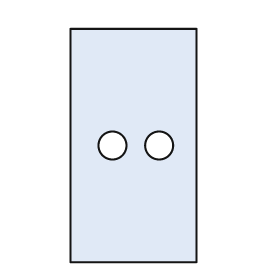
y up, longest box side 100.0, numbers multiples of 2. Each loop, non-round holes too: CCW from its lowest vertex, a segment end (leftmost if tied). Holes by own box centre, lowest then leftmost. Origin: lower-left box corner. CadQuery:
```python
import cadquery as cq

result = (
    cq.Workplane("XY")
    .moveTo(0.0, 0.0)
    .lineTo(54.0, 0.0)
    .lineTo(54.0, 100.0)
    .lineTo(0.0, 100.0)
    .close()
    .moveTo(18.0, 50.0)
    .circle(6.0)
    .moveTo(38.0, 50.0)
    .circle(6.0)
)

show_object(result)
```